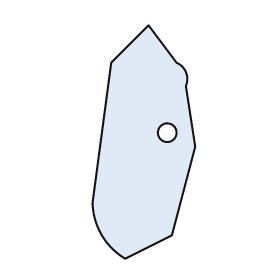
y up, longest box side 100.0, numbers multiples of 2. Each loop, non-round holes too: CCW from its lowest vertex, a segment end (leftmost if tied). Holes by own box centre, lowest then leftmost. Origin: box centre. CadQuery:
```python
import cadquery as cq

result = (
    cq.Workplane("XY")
    .moveTo(-8.0, -50.0)
    .lineTo(12.0, -40.0)
    .lineTo(22.0, -2.0)
    .lineTo(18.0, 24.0)
    .threePointArc((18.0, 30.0), (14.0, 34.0))
    .lineTo(2.0, 50.0)
    .lineTo(-14.0, 34.0)
    .lineTo(-22.0, -26.0)
    .threePointArc((-18.0, -40.0), (-8.0, -50.0))
    .close()
    .moveTo(10.0, 4.0)
    .circle(4.0)
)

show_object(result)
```